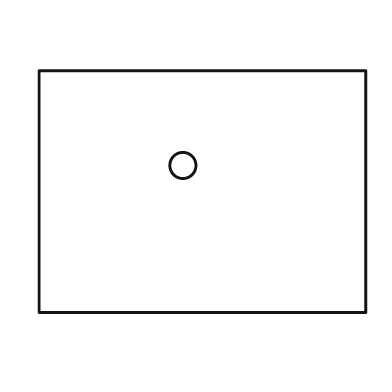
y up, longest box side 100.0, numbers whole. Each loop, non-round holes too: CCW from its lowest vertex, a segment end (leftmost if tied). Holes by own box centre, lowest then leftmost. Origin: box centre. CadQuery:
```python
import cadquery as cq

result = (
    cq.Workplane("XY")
    .moveTo(-50.0, -37.0)
    .lineTo(50.0, -37.0)
    .lineTo(50.0, 37.0)
    .lineTo(-50.0, 37.0)
    .close()
    .moveTo(-6.0, 8.0)
    .circle(4.0)
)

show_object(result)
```